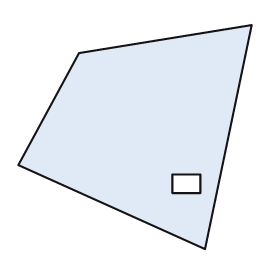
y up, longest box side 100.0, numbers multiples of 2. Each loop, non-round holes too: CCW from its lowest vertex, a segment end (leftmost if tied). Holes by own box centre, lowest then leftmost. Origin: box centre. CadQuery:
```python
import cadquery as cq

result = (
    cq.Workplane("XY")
    .moveTo(30.0, -48.0)
    .lineTo(50.0, 48.0)
    .lineTo(-24.0, 36.0)
    .lineTo(-50.0, -12.0)
    .close()
    .moveTo(16.0, -24.0)
    .lineTo(28.0, -24.0)
    .lineTo(28.0, -16.0)
    .lineTo(16.0, -16.0)
    .close()
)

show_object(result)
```